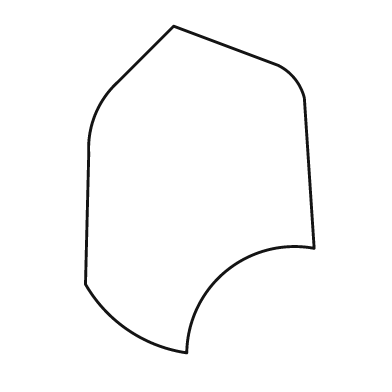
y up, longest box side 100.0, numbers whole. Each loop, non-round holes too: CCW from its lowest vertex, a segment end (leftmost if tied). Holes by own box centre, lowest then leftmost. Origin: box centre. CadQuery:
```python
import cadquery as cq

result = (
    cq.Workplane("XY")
    .moveTo(-4.0, -50.0)
    .threePointArc((8.0, -25.0), (35.0, -18.0))
    .lineTo(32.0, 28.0)
    .threePointArc((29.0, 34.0), (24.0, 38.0))
    .lineTo(-8.0, 50.0)
    .lineTo(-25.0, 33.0)
    .threePointArc((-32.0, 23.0), (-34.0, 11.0))
    .lineTo(-35.0, -29.0)
    .threePointArc((-22.0, -43.0), (-4.0, -50.0))
    .close()
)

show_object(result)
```